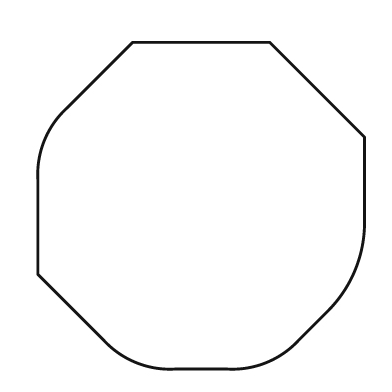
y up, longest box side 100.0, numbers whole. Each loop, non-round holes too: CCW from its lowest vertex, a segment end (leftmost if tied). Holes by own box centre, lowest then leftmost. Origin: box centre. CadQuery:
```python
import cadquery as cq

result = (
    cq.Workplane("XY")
    .moveTo(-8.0, -50.0)
    .lineTo(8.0, -50.0)
    .threePointArc((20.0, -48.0), (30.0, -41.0))
    .lineTo(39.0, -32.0)
    .threePointArc((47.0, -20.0), (50.0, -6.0))
    .lineTo(50.0, 21.0)
    .lineTo(21.0, 50.0)
    .lineTo(-21.0, 50.0)
    .lineTo(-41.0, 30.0)
    .threePointArc((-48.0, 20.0), (-50.0, 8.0))
    .lineTo(-50.0, -21.0)
    .lineTo(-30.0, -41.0)
    .threePointArc((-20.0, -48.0), (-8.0, -50.0))
    .close()
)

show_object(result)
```